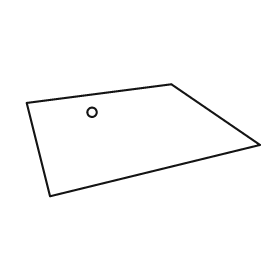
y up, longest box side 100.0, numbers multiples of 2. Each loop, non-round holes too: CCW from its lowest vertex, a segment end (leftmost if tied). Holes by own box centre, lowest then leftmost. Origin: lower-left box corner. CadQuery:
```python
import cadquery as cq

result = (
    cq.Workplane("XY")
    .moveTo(10.0, 0.0)
    .lineTo(100.0, 22.0)
    .lineTo(62.0, 48.0)
    .lineTo(0.0, 40.0)
    .close()
    .moveTo(28.0, 36.0)
    .circle(2.0)
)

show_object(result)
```